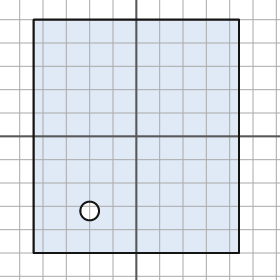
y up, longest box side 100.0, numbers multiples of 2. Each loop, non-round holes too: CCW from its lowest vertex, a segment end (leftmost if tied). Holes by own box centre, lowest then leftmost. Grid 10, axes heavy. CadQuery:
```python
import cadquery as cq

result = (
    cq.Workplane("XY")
    .moveTo(-44.0, -50.0)
    .lineTo(44.0, -50.0)
    .lineTo(44.0, 50.0)
    .lineTo(-44.0, 50.0)
    .close()
    .moveTo(-20.0, -32.0)
    .circle(4.0)
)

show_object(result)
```